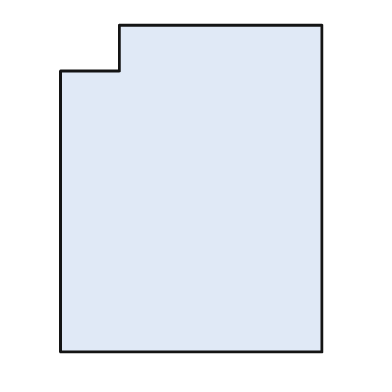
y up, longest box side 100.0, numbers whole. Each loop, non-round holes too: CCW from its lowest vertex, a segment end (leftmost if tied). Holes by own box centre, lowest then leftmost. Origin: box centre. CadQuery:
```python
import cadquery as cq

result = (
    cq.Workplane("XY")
    .moveTo(-40.0, -50.0)
    .lineTo(40.0, -50.0)
    .lineTo(40.0, 50.0)
    .lineTo(-22.0, 50.0)
    .lineTo(-22.0, 36.0)
    .lineTo(-40.0, 36.0)
    .close()
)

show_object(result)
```